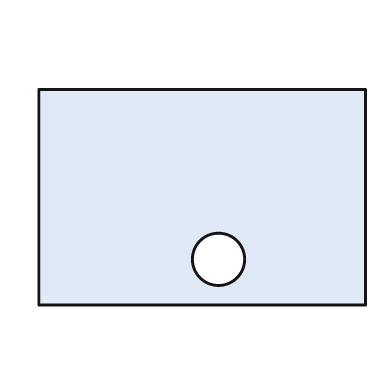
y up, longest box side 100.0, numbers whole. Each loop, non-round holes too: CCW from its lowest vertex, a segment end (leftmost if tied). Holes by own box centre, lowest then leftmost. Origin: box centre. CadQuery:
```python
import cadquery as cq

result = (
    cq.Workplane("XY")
    .moveTo(-50.0, -33.0)
    .lineTo(50.0, -33.0)
    .lineTo(50.0, 33.0)
    .lineTo(-50.0, 33.0)
    .close()
    .moveTo(5.0, -19.0)
    .circle(8.0)
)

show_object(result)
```